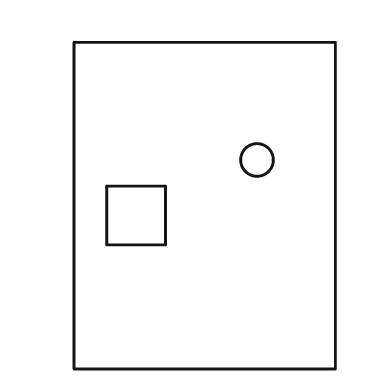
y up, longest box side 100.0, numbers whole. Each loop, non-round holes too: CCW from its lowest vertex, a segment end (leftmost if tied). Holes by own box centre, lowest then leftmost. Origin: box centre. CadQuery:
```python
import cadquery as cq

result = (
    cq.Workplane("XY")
    .moveTo(-40.0, -50.0)
    .lineTo(40.0, -50.0)
    .lineTo(40.0, 50.0)
    .lineTo(-40.0, 50.0)
    .close()
    .moveTo(-30.0, -12.0)
    .lineTo(-12.0, -12.0)
    .lineTo(-12.0, 6.0)
    .lineTo(-30.0, 6.0)
    .close()
    .moveTo(16.0, 14.0)
    .circle(5.0)
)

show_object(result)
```